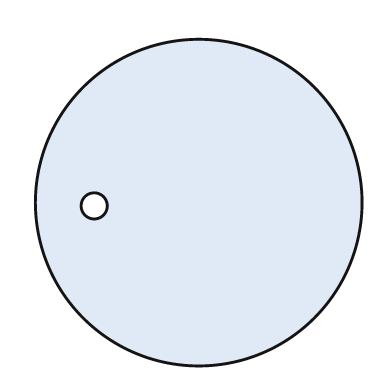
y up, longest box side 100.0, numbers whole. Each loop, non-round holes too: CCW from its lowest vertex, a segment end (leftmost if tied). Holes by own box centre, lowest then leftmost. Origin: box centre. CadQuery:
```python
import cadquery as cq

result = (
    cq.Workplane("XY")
    .moveTo(0.0, 0.0)
    .circle(50.0)
    .moveTo(-32.0, -1.0)
    .circle(4.0)
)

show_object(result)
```